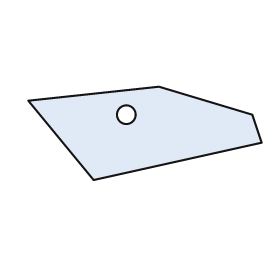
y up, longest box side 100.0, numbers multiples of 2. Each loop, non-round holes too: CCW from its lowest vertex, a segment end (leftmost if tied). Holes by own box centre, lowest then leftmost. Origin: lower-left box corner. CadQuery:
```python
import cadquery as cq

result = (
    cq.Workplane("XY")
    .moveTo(28.0, 0.0)
    .lineTo(100.0, 16.0)
    .lineTo(96.0, 28.0)
    .lineTo(56.0, 40.0)
    .lineTo(0.0, 34.0)
    .close()
    .moveTo(42.0, 28.0)
    .circle(4.0)
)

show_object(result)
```